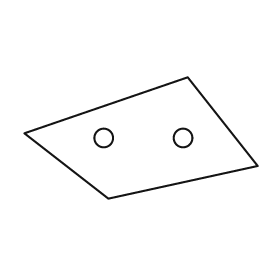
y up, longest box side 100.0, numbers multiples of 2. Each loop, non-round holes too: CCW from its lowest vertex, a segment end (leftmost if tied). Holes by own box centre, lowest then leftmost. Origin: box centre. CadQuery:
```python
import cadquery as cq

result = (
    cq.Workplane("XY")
    .moveTo(-14.0, -26.0)
    .lineTo(50.0, -12.0)
    .lineTo(20.0, 26.0)
    .lineTo(-50.0, 2.0)
    .close()
    .moveTo(-16.0, 0.0)
    .circle(4.0)
    .moveTo(18.0, 0.0)
    .circle(4.0)
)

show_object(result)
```